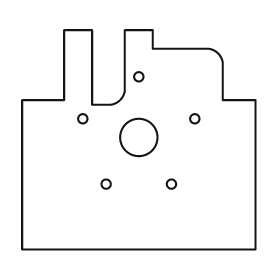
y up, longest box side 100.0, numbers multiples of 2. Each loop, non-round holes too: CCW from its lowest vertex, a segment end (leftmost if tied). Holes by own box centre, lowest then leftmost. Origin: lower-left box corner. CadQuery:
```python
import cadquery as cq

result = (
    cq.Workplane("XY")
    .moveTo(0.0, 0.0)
    .lineTo(100.0, 0.0)
    .lineTo(100.0, 64.0)
    .lineTo(86.0, 64.0)
    .lineTo(86.0, 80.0)
    .threePointArc((84.0, 84.0), (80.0, 86.0))
    .lineTo(56.0, 86.0)
    .lineTo(56.0, 94.0)
    .lineTo(44.0, 94.0)
    .lineTo(44.0, 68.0)
    .threePointArc((42.0, 64.0), (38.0, 62.0))
    .lineTo(30.0, 62.0)
    .lineTo(30.0, 94.0)
    .lineTo(18.0, 94.0)
    .lineTo(18.0, 64.0)
    .lineTo(0.0, 64.0)
    .close()
    .moveTo(36.0, 28.0)
    .circle(2.0)
    .moveTo(64.0, 28.0)
    .circle(2.0)
    .moveTo(50.0, 48.0)
    .circle(8.0)
    .moveTo(26.0, 56.0)
    .circle(2.0)
    .moveTo(74.0, 56.0)
    .circle(2.0)
    .moveTo(50.0, 74.0)
    .circle(2.0)
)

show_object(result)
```